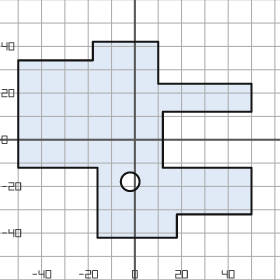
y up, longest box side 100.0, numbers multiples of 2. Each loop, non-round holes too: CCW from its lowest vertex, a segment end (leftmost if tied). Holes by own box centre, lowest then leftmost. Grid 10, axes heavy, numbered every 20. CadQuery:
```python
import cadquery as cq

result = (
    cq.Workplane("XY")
    .moveTo(-16.0, -42.0)
    .lineTo(18.0, -42.0)
    .lineTo(18.0, -32.0)
    .lineTo(50.0, -32.0)
    .lineTo(50.0, -12.0)
    .lineTo(12.0, -12.0)
    .lineTo(12.0, 12.0)
    .lineTo(50.0, 12.0)
    .lineTo(50.0, 24.0)
    .lineTo(10.0, 24.0)
    .lineTo(10.0, 42.0)
    .lineTo(-18.0, 42.0)
    .lineTo(-18.0, 34.0)
    .lineTo(-50.0, 34.0)
    .lineTo(-50.0, -12.0)
    .lineTo(-16.0, -12.0)
    .close()
    .moveTo(-2.0, -18.0)
    .circle(4.0)
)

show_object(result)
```